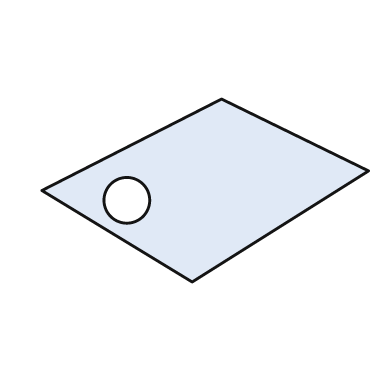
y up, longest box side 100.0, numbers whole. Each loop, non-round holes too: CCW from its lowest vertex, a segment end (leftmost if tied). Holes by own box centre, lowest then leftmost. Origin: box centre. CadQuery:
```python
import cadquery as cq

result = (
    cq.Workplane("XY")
    .moveTo(-4.0, -28.0)
    .lineTo(50.0, 6.0)
    .lineTo(5.0, 28.0)
    .lineTo(-50.0, 0.0)
    .close()
    .moveTo(-24.0, -3.0)
    .circle(7.0)
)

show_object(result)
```